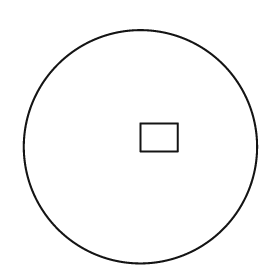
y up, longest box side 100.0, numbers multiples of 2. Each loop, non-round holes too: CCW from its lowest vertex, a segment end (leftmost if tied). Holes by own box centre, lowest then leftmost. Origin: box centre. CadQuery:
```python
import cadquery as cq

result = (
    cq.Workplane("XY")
    .moveTo(0.0, 0.0)
    .circle(50.0)
    .moveTo(0.0, -2.0)
    .lineTo(16.0, -2.0)
    .lineTo(16.0, 10.0)
    .lineTo(0.0, 10.0)
    .close()
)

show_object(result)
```